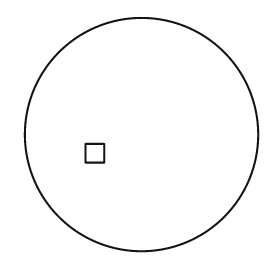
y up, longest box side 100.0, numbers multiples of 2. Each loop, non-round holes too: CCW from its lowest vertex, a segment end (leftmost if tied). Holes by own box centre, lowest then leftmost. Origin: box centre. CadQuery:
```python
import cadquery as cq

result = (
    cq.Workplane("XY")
    .moveTo(0.0, 0.0)
    .circle(50.0)
    .moveTo(-24.0, -12.0)
    .lineTo(-16.0, -12.0)
    .lineTo(-16.0, -4.0)
    .lineTo(-24.0, -4.0)
    .close()
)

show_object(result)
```